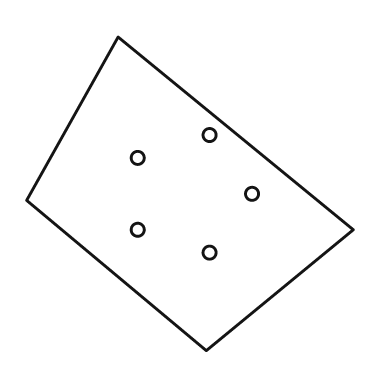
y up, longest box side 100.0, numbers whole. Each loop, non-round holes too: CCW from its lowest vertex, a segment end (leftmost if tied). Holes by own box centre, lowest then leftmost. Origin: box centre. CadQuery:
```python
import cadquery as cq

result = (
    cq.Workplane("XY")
    .moveTo(5.0, -48.0)
    .lineTo(50.0, -11.0)
    .lineTo(-22.0, 48.0)
    .lineTo(-50.0, -2.0)
    .close()
    .moveTo(6.0, -18.0)
    .circle(2.0)
    .moveTo(-16.0, -11.0)
    .circle(2.0)
    .moveTo(19.0, 0.0)
    .circle(2.0)
    .moveTo(-16.0, 11.0)
    .circle(2.0)
    .moveTo(6.0, 18.0)
    .circle(2.0)
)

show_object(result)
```